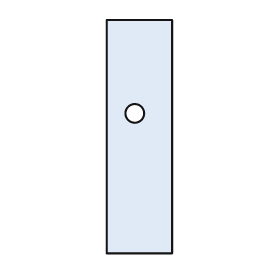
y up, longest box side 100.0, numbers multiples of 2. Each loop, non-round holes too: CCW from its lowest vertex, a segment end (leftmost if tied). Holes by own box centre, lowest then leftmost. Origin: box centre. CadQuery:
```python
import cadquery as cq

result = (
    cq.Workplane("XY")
    .moveTo(-14.0, -50.0)
    .lineTo(14.0, -50.0)
    .lineTo(14.0, 50.0)
    .lineTo(-14.0, 50.0)
    .close()
    .moveTo(-2.0, 10.0)
    .circle(4.0)
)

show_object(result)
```